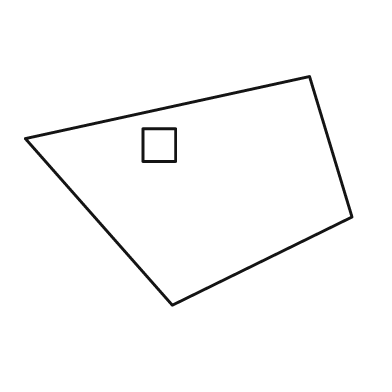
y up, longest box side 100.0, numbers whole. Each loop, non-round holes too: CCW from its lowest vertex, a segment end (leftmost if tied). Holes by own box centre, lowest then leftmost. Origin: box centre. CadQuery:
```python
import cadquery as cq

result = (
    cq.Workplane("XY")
    .moveTo(-5.0, -35.0)
    .lineTo(50.0, -8.0)
    .lineTo(37.0, 35.0)
    .lineTo(-50.0, 16.0)
    .close()
    .moveTo(-14.0, 9.0)
    .lineTo(-4.0, 9.0)
    .lineTo(-4.0, 19.0)
    .lineTo(-14.0, 19.0)
    .close()
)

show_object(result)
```